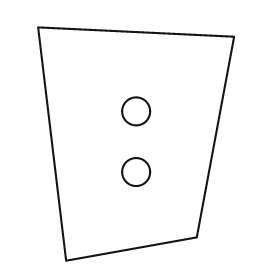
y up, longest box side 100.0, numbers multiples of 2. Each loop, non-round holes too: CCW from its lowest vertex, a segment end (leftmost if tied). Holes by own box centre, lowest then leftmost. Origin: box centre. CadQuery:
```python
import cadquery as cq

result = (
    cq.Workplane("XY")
    .moveTo(-30.0, -50.0)
    .lineTo(26.0, -40.0)
    .lineTo(42.0, 46.0)
    .lineTo(-42.0, 50.0)
    .close()
    .moveTo(0.0, -12.0)
    .circle(6.0)
    .moveTo(0.0, 14.0)
    .circle(6.0)
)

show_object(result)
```